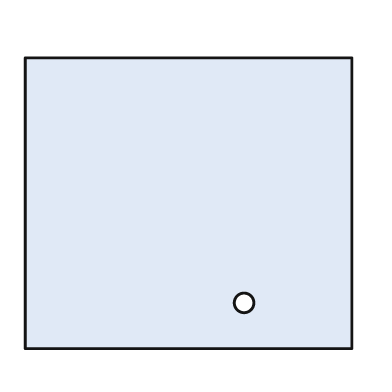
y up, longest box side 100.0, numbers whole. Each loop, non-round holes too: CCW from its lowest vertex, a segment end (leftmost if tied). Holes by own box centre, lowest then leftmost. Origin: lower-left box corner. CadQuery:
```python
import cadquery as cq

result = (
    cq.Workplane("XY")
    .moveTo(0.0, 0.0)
    .lineTo(100.0, 0.0)
    .lineTo(100.0, 89.0)
    .lineTo(0.0, 89.0)
    .close()
    .moveTo(67.0, 14.0)
    .circle(3.0)
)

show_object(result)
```